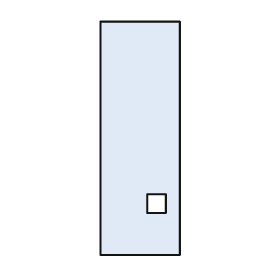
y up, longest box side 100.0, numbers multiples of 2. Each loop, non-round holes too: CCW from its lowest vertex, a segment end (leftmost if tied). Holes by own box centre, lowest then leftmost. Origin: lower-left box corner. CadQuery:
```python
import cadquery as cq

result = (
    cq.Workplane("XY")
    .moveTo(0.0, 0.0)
    .lineTo(34.0, 0.0)
    .lineTo(34.0, 100.0)
    .lineTo(0.0, 100.0)
    .close()
    .moveTo(20.0, 18.0)
    .lineTo(28.0, 18.0)
    .lineTo(28.0, 26.0)
    .lineTo(20.0, 26.0)
    .close()
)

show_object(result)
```